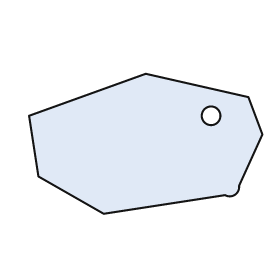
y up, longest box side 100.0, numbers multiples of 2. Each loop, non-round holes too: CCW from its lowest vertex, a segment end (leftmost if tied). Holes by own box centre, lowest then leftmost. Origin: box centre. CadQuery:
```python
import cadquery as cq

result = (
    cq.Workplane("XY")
    .moveTo(-18.0, -30.0)
    .lineTo(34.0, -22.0)
    .threePointArc((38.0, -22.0), (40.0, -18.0))
    .lineTo(50.0, 4.0)
    .lineTo(44.0, 20.0)
    .lineTo(0.0, 30.0)
    .lineTo(-50.0, 12.0)
    .lineTo(-46.0, -14.0)
    .close()
    .moveTo(28.0, 12.0)
    .circle(4.0)
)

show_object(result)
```